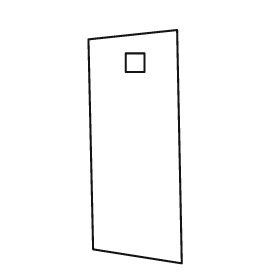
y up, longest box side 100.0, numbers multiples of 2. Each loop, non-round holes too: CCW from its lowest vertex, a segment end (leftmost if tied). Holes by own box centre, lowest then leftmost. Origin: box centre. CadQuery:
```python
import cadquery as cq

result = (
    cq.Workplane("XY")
    .moveTo(20.0, -50.0)
    .lineTo(18.0, 50.0)
    .lineTo(-20.0, 46.0)
    .lineTo(-18.0, -44.0)
    .close()
    .moveTo(-4.0, 32.0)
    .lineTo(4.0, 32.0)
    .lineTo(4.0, 40.0)
    .lineTo(-4.0, 40.0)
    .close()
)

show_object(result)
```